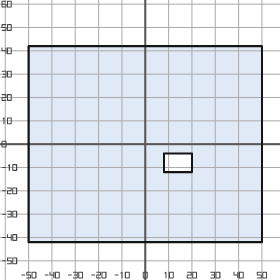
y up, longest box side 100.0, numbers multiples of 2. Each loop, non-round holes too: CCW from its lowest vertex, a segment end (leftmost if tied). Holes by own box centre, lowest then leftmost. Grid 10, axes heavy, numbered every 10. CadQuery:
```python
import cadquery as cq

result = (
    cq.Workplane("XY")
    .moveTo(-50.0, -42.0)
    .lineTo(50.0, -42.0)
    .lineTo(50.0, 42.0)
    .lineTo(-50.0, 42.0)
    .close()
    .moveTo(8.0, -12.0)
    .lineTo(20.0, -12.0)
    .lineTo(20.0, -4.0)
    .lineTo(8.0, -4.0)
    .close()
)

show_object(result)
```